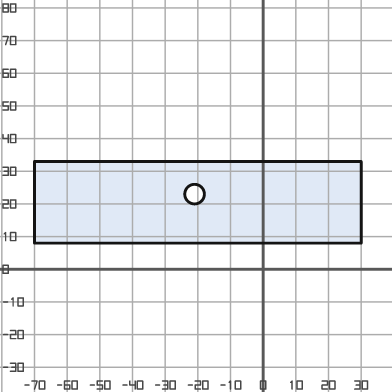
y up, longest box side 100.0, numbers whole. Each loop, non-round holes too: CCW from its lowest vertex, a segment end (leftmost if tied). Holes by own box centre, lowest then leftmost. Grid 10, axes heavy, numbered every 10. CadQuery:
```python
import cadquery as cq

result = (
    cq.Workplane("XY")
    .moveTo(-70.0, 8.0)
    .lineTo(30.0, 8.0)
    .lineTo(30.0, 33.0)
    .lineTo(-70.0, 33.0)
    .close()
    .moveTo(-21.0, 23.0)
    .circle(3.0)
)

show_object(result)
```